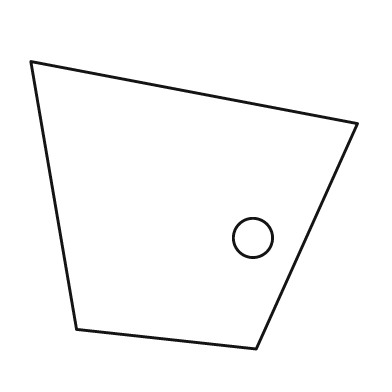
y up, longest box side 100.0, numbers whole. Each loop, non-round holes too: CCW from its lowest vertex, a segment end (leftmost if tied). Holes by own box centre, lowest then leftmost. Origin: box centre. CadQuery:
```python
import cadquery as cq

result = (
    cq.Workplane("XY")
    .moveTo(19.0, -44.0)
    .lineTo(50.0, 25.0)
    .lineTo(-50.0, 44.0)
    .lineTo(-36.0, -38.0)
    .close()
    .moveTo(18.0, -10.0)
    .circle(6.0)
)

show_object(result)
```